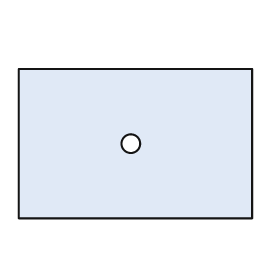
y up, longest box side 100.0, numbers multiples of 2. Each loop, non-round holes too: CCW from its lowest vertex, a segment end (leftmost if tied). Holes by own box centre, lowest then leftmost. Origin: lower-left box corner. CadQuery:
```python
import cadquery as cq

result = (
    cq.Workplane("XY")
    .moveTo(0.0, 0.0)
    .lineTo(100.0, 0.0)
    .lineTo(100.0, 64.0)
    .lineTo(0.0, 64.0)
    .close()
    .moveTo(48.0, 32.0)
    .circle(4.0)
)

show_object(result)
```